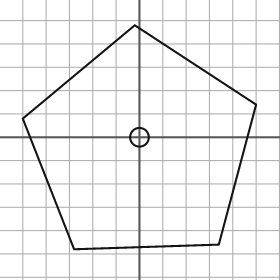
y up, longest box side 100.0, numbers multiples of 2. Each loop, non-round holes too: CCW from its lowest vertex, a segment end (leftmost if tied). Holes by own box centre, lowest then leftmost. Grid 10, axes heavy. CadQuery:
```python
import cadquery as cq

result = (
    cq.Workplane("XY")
    .moveTo(-28.0, -48.0)
    .lineTo(34.0, -46.0)
    .lineTo(50.0, 14.0)
    .lineTo(-2.0, 48.0)
    .lineTo(-50.0, 8.0)
    .close()
    .moveTo(0.0, 0.0)
    .circle(4.0)
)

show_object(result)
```